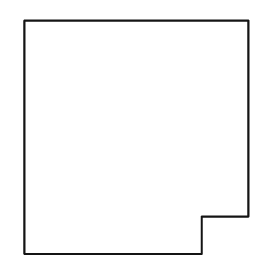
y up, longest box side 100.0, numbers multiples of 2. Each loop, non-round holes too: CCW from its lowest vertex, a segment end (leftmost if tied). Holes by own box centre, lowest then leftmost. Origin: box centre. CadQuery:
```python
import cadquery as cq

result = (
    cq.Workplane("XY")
    .moveTo(-48.0, -50.0)
    .lineTo(28.0, -50.0)
    .lineTo(28.0, -34.0)
    .lineTo(48.0, -34.0)
    .lineTo(48.0, 50.0)
    .lineTo(-48.0, 50.0)
    .close()
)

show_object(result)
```